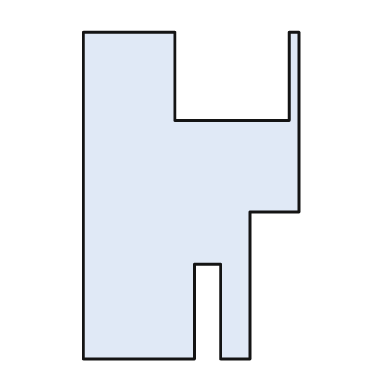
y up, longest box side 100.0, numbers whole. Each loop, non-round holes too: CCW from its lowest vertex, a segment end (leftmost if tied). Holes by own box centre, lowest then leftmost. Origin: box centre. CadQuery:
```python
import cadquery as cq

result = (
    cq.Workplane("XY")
    .moveTo(-33.0, -50.0)
    .lineTo(1.0, -50.0)
    .lineTo(1.0, -21.0)
    .lineTo(9.0, -21.0)
    .lineTo(9.0, -50.0)
    .lineTo(18.0, -50.0)
    .lineTo(18.0, -5.0)
    .lineTo(33.0, -5.0)
    .lineTo(33.0, 50.0)
    .lineTo(30.0, 50.0)
    .lineTo(30.0, 23.0)
    .lineTo(-5.0, 23.0)
    .lineTo(-5.0, 50.0)
    .lineTo(-33.0, 50.0)
    .close()
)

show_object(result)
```